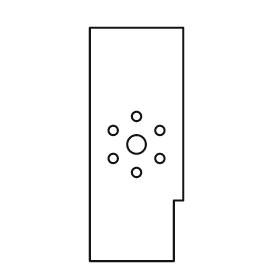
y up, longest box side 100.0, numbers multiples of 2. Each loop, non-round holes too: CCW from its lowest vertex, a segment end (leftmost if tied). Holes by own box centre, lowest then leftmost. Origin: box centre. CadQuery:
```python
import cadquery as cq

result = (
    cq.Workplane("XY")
    .moveTo(-20.0, -50.0)
    .lineTo(16.0, -50.0)
    .lineTo(16.0, -24.0)
    .lineTo(20.0, -24.0)
    .lineTo(20.0, 50.0)
    .lineTo(-20.0, 50.0)
    .close()
    .moveTo(0.0, -12.0)
    .circle(2.0)
    .moveTo(-10.0, -6.0)
    .circle(2.0)
    .moveTo(10.0, -6.0)
    .circle(2.0)
    .moveTo(0.0, 0.0)
    .circle(4.0)
    .moveTo(-10.0, 6.0)
    .circle(2.0)
    .moveTo(10.0, 6.0)
    .circle(2.0)
    .moveTo(0.0, 12.0)
    .circle(2.0)
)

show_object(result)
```